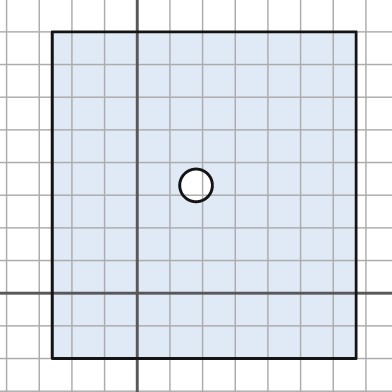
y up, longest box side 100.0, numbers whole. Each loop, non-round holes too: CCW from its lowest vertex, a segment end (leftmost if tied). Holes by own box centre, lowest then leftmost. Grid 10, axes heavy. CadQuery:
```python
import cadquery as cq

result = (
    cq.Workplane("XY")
    .moveTo(-26.0, -20.0)
    .lineTo(67.0, -20.0)
    .lineTo(67.0, 80.0)
    .lineTo(-26.0, 80.0)
    .close()
    .moveTo(18.0, 33.0)
    .circle(5.0)
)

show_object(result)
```